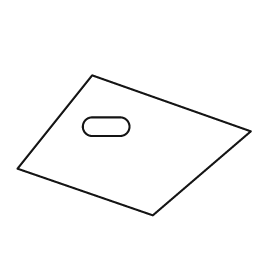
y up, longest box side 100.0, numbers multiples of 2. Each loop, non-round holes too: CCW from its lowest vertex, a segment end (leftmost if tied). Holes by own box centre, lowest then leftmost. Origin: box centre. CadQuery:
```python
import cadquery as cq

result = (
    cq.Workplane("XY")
    .moveTo(8.0, -30.0)
    .lineTo(50.0, 6.0)
    .lineTo(-18.0, 30.0)
    .lineTo(-50.0, -10.0)
    .close()
    .moveTo(-18.0, 4.0)
    .lineTo(-6.0, 4.0)
    .threePointArc((-2.0, 8.0), (-6.0, 12.0))
    .lineTo(-18.0, 12.0)
    .threePointArc((-22.0, 8.0), (-18.0, 4.0))
    .close()
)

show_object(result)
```